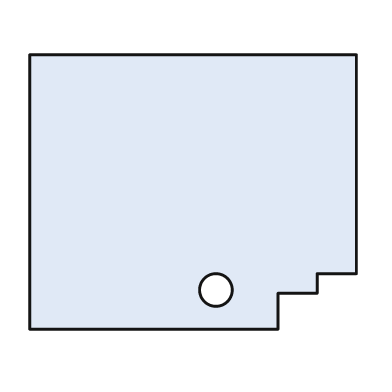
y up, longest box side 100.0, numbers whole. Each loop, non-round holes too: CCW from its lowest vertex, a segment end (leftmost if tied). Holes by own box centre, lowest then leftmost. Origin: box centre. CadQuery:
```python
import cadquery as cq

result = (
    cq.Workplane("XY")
    .moveTo(-50.0, -42.0)
    .lineTo(26.0, -42.0)
    .lineTo(26.0, -31.0)
    .lineTo(38.0, -31.0)
    .lineTo(38.0, -25.0)
    .lineTo(50.0, -25.0)
    .lineTo(50.0, 42.0)
    .lineTo(-50.0, 42.0)
    .close()
    .moveTo(7.0, -30.0)
    .circle(5.0)
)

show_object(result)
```